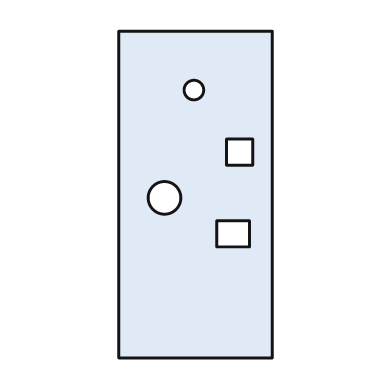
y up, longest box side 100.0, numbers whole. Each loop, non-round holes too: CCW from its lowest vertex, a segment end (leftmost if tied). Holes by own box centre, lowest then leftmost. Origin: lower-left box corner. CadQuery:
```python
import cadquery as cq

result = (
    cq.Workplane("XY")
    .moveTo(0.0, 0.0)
    .lineTo(47.0, 0.0)
    .lineTo(47.0, 100.0)
    .lineTo(0.0, 100.0)
    .close()
    .moveTo(30.0, 34.0)
    .lineTo(40.0, 34.0)
    .lineTo(40.0, 42.0)
    .lineTo(30.0, 42.0)
    .close()
    .moveTo(14.0, 49.0)
    .circle(5.0)
    .moveTo(33.0, 59.0)
    .lineTo(41.0, 59.0)
    .lineTo(41.0, 67.0)
    .lineTo(33.0, 67.0)
    .close()
    .moveTo(23.0, 82.0)
    .circle(3.0)
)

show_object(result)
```